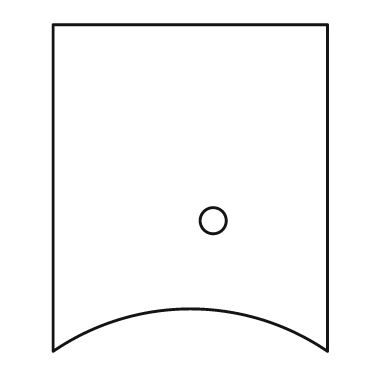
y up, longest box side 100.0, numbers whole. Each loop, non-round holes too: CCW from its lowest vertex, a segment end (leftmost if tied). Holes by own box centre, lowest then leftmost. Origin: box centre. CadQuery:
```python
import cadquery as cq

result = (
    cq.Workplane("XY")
    .moveTo(-42.0, -50.0)
    .threePointArc((0.0, -37.0), (42.0, -50.0))
    .lineTo(42.0, 50.0)
    .lineTo(-42.0, 50.0)
    .close()
    .moveTo(7.0, -10.0)
    .circle(4.0)
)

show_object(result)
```